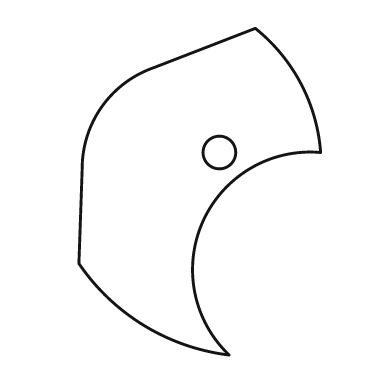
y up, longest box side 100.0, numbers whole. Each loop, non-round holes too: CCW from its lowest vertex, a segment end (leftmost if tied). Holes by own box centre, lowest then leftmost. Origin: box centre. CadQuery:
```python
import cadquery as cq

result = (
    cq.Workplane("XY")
    .moveTo(9.0, -50.0)
    .threePointArc((1.0, -9.0), (37.0, 12.0))
    .threePointArc((31.0, 33.0), (17.0, 50.0))
    .lineTo(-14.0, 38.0)
    .threePointArc((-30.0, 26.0), (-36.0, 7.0))
    .lineTo(-37.0, -22.0)
    .threePointArc((-17.0, -41.0), (9.0, -50.0))
    .close()
    .moveTo(6.0, 12.0)
    .circle(5.0)
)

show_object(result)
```